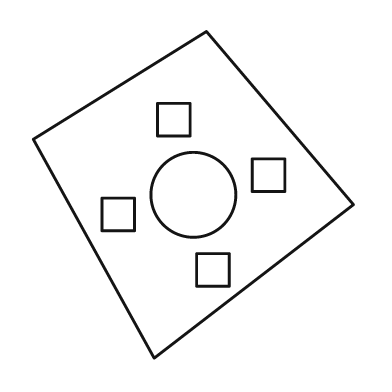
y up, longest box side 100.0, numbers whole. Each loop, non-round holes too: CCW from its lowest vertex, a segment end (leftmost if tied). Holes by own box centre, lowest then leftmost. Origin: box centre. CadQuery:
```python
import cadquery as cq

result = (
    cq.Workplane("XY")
    .moveTo(-12.0, -50.0)
    .lineTo(49.0, -3.0)
    .lineTo(4.0, 50.0)
    .lineTo(-49.0, 17.0)
    .close()
    .moveTo(1.0, -28.0)
    .lineTo(11.0, -28.0)
    .lineTo(11.0, -18.0)
    .lineTo(1.0, -18.0)
    .close()
    .moveTo(-28.0, -11.0)
    .lineTo(-18.0, -11.0)
    .lineTo(-18.0, -1.0)
    .lineTo(-28.0, -1.0)
    .close()
    .moveTo(0.0, 0.0)
    .circle(13.0)
    .moveTo(18.0, 1.0)
    .lineTo(28.0, 1.0)
    .lineTo(28.0, 11.0)
    .lineTo(18.0, 11.0)
    .close()
    .moveTo(-11.0, 18.0)
    .lineTo(-1.0, 18.0)
    .lineTo(-1.0, 28.0)
    .lineTo(-11.0, 28.0)
    .close()
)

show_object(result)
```